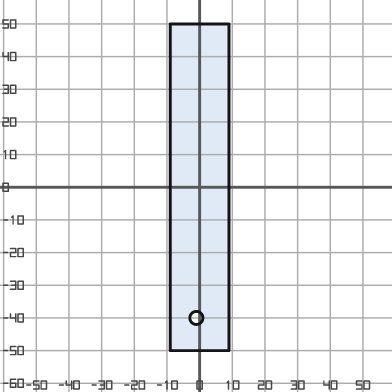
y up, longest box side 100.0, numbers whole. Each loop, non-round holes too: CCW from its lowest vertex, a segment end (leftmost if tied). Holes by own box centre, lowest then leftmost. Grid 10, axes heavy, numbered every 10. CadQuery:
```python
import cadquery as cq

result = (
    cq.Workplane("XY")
    .moveTo(-9.0, -50.0)
    .lineTo(9.0, -50.0)
    .lineTo(9.0, 50.0)
    .lineTo(-9.0, 50.0)
    .close()
    .moveTo(-1.0, -40.0)
    .circle(2.0)
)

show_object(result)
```